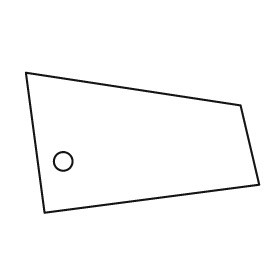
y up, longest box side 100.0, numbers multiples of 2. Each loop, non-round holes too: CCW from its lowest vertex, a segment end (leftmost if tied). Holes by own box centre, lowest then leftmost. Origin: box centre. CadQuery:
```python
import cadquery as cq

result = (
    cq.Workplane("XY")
    .moveTo(-42.0, -30.0)
    .lineTo(50.0, -18.0)
    .lineTo(42.0, 16.0)
    .lineTo(-50.0, 30.0)
    .close()
    .moveTo(-34.0, -8.0)
    .circle(4.0)
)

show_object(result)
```